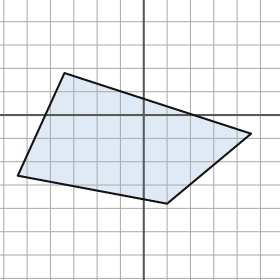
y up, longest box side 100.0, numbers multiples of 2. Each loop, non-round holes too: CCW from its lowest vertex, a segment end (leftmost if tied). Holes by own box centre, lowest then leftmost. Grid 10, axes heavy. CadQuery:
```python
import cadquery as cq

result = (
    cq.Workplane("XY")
    .moveTo(10.0, -38.0)
    .lineTo(46.0, -8.0)
    .lineTo(-34.0, 18.0)
    .lineTo(-54.0, -26.0)
    .close()
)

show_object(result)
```